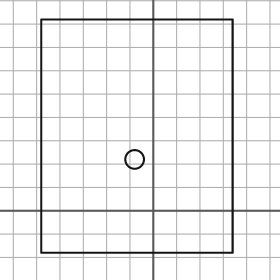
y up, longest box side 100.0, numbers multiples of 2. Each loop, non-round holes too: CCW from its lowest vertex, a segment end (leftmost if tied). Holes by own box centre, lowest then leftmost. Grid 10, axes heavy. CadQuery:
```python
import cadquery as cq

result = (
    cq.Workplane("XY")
    .moveTo(-48.0, -18.0)
    .lineTo(34.0, -18.0)
    .lineTo(34.0, 82.0)
    .lineTo(-48.0, 82.0)
    .close()
    .moveTo(-8.0, 22.0)
    .circle(4.0)
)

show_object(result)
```